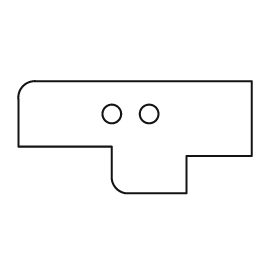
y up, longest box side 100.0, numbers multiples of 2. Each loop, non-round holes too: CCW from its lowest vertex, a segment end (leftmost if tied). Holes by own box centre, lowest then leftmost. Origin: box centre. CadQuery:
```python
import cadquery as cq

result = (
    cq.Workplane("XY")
    .moveTo(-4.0, -24.0)
    .lineTo(22.0, -24.0)
    .lineTo(22.0, -8.0)
    .lineTo(50.0, -8.0)
    .lineTo(50.0, 24.0)
    .lineTo(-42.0, 24.0)
    .threePointArc((-48.0, 22.0), (-50.0, 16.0))
    .lineTo(-50.0, -4.0)
    .lineTo(-10.0, -4.0)
    .lineTo(-10.0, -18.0)
    .threePointArc((-8.0, -22.0), (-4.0, -24.0))
    .close()
    .moveTo(-10.0, 10.0)
    .circle(4.0)
    .moveTo(6.0, 10.0)
    .circle(4.0)
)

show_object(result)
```